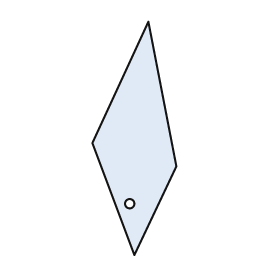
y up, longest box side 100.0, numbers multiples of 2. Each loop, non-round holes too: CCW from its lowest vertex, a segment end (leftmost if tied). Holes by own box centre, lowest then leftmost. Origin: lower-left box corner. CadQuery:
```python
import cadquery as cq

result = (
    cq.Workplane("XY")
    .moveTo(18.0, 0.0)
    .lineTo(36.0, 38.0)
    .lineTo(24.0, 100.0)
    .lineTo(0.0, 48.0)
    .close()
    .moveTo(16.0, 22.0)
    .circle(2.0)
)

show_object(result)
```